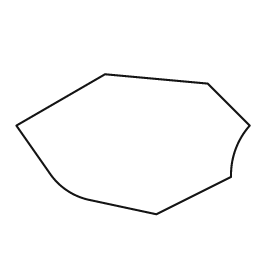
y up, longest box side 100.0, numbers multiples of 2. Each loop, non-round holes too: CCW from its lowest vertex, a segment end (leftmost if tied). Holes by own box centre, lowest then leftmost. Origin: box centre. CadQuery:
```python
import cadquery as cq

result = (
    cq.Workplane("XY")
    .moveTo(10.0, -30.0)
    .lineTo(42.0, -14.0)
    .threePointArc((44.0, -2.0), (50.0, 8.0))
    .lineTo(32.0, 26.0)
    .lineTo(-12.0, 30.0)
    .lineTo(-50.0, 8.0)
    .lineTo(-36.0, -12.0)
    .threePointArc((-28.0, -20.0), (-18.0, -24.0))
    .close()
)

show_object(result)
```